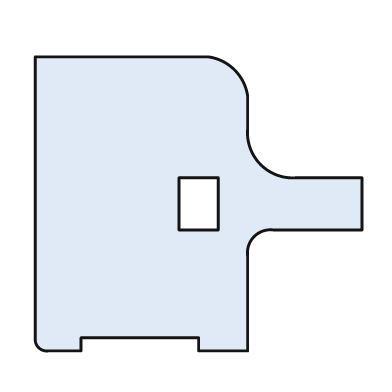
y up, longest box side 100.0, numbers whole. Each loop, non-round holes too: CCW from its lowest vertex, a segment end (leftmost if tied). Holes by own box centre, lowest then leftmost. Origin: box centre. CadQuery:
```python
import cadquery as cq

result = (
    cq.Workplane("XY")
    .moveTo(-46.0, -45.0)
    .lineTo(-36.0, -45.0)
    .lineTo(-36.0, -41.0)
    .lineTo(0.0, -41.0)
    .lineTo(0.0, -45.0)
    .lineTo(15.0, -45.0)
    .lineTo(15.0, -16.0)
    .threePointArc((17.0, -10.0), (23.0, -8.0))
    .lineTo(50.0, -8.0)
    .lineTo(50.0, 8.0)
    .lineTo(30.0, 8.0)
    .threePointArc((19.0, 12.0), (15.0, 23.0))
    .lineTo(15.0, 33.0)
    .threePointArc((11.0, 41.0), (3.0, 45.0))
    .lineTo(-50.0, 45.0)
    .lineTo(-50.0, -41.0)
    .threePointArc((-49.0, -44.0), (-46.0, -45.0))
    .close()
    .moveTo(-6.0, -8.0)
    .lineTo(6.0, -8.0)
    .lineTo(6.0, 8.0)
    .lineTo(-6.0, 8.0)
    .close()
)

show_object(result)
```